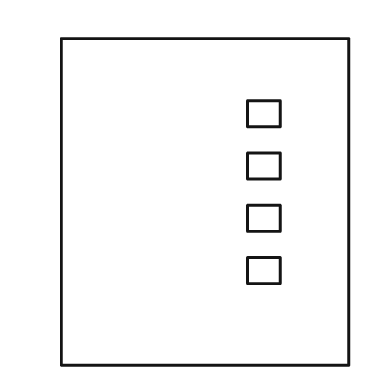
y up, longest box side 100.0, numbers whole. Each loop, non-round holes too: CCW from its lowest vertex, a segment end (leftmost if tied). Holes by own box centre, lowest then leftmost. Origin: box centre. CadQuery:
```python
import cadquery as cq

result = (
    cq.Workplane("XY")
    .moveTo(-44.0, -50.0)
    .lineTo(44.0, -50.0)
    .lineTo(44.0, 50.0)
    .lineTo(-44.0, 50.0)
    .close()
    .moveTo(13.0, -25.0)
    .lineTo(23.0, -25.0)
    .lineTo(23.0, -17.0)
    .lineTo(13.0, -17.0)
    .close()
    .moveTo(13.0, -9.0)
    .lineTo(23.0, -9.0)
    .lineTo(23.0, -1.0)
    .lineTo(13.0, -1.0)
    .close()
    .moveTo(13.0, 7.0)
    .lineTo(23.0, 7.0)
    .lineTo(23.0, 15.0)
    .lineTo(13.0, 15.0)
    .close()
    .moveTo(13.0, 23.0)
    .lineTo(23.0, 23.0)
    .lineTo(23.0, 31.0)
    .lineTo(13.0, 31.0)
    .close()
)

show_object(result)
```